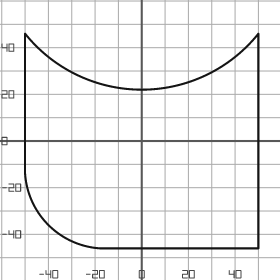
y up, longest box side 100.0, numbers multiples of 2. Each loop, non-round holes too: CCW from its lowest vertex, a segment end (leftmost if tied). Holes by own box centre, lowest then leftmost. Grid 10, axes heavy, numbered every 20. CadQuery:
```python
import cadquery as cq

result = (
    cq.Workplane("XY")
    .moveTo(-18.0, -46.0)
    .lineTo(50.0, -46.0)
    .lineTo(50.0, 46.0)
    .threePointArc((0.0, 22.0), (-50.0, 46.0))
    .lineTo(-50.0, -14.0)
    .threePointArc((-40.0, -36.0), (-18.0, -46.0))
    .close()
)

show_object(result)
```